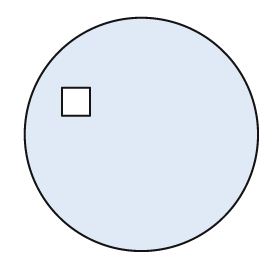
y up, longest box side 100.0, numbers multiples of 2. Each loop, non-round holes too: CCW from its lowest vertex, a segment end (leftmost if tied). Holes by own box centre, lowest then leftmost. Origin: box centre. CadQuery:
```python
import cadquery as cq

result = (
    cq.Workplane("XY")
    .moveTo(0.0, 0.0)
    .circle(50.0)
    .moveTo(-34.0, 8.0)
    .lineTo(-22.0, 8.0)
    .lineTo(-22.0, 20.0)
    .lineTo(-34.0, 20.0)
    .close()
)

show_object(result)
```